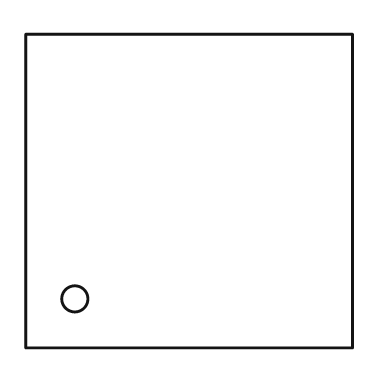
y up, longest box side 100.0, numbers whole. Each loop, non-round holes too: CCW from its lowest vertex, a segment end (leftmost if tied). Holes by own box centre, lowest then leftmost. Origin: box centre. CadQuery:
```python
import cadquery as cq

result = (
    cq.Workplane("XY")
    .moveTo(-50.0, -48.0)
    .lineTo(50.0, -48.0)
    .lineTo(50.0, 48.0)
    .lineTo(-50.0, 48.0)
    .close()
    .moveTo(-35.0, -33.0)
    .circle(4.0)
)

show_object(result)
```